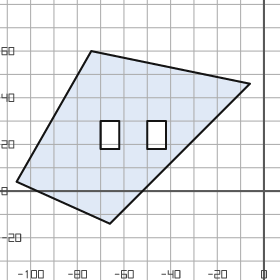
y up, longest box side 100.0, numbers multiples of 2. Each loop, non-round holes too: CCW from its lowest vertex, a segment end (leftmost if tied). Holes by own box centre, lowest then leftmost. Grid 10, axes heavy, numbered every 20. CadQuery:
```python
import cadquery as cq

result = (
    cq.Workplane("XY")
    .moveTo(-66.0, -14.0)
    .lineTo(-6.0, 46.0)
    .lineTo(-74.0, 60.0)
    .lineTo(-106.0, 4.0)
    .close()
    .moveTo(-70.0, 18.0)
    .lineTo(-62.0, 18.0)
    .lineTo(-62.0, 30.0)
    .lineTo(-70.0, 30.0)
    .close()
    .moveTo(-50.0, 18.0)
    .lineTo(-42.0, 18.0)
    .lineTo(-42.0, 30.0)
    .lineTo(-50.0, 30.0)
    .close()
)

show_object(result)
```